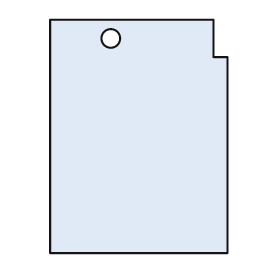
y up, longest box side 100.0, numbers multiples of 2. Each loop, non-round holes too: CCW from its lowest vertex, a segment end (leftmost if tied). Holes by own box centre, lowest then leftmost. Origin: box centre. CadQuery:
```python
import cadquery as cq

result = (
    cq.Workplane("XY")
    .moveTo(-38.0, -50.0)
    .lineTo(38.0, -50.0)
    .lineTo(38.0, 34.0)
    .lineTo(32.0, 34.0)
    .lineTo(32.0, 50.0)
    .lineTo(-38.0, 50.0)
    .close()
    .moveTo(-12.0, 42.0)
    .circle(4.0)
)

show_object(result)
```